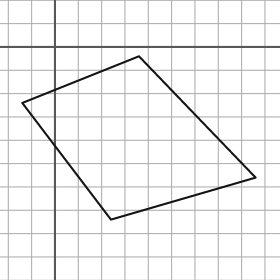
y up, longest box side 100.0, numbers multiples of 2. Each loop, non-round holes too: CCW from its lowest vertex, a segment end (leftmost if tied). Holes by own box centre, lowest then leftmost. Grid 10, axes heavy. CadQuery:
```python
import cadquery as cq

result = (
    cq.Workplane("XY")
    .moveTo(24.0, -74.0)
    .lineTo(86.0, -56.0)
    .lineTo(36.0, -4.0)
    .lineTo(-14.0, -24.0)
    .close()
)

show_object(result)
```